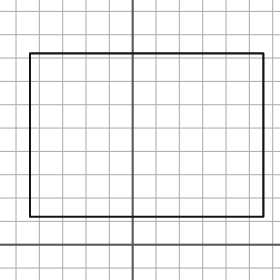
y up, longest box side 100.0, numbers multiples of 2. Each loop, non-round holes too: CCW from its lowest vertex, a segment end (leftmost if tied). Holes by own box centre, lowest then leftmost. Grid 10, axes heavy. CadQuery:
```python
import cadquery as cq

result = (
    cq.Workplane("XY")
    .moveTo(-44.0, 12.0)
    .lineTo(56.0, 12.0)
    .lineTo(56.0, 82.0)
    .lineTo(-44.0, 82.0)
    .close()
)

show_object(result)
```